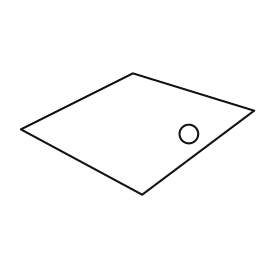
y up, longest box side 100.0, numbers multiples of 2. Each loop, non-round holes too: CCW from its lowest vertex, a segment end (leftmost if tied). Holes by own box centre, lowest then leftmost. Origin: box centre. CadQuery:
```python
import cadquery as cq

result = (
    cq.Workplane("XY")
    .moveTo(2.0, -26.0)
    .lineTo(50.0, 10.0)
    .lineTo(-2.0, 26.0)
    .lineTo(-50.0, 2.0)
    .close()
    .moveTo(22.0, 0.0)
    .circle(4.0)
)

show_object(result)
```